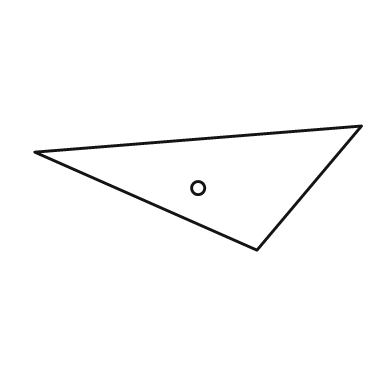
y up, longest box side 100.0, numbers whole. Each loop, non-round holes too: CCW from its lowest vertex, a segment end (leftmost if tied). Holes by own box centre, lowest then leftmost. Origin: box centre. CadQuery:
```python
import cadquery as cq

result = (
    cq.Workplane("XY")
    .moveTo(18.0, -19.0)
    .lineTo(50.0, 19.0)
    .lineTo(-50.0, 11.0)
    .close()
    .moveTo(0.0, 0.0)
    .circle(2.0)
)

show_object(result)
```